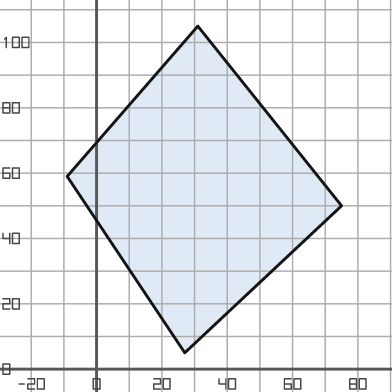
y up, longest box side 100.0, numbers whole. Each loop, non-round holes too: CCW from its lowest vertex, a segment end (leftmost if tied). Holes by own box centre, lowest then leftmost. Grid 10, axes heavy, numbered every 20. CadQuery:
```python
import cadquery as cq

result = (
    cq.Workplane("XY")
    .moveTo(27.0, 5.0)
    .lineTo(75.0, 50.0)
    .lineTo(31.0, 105.0)
    .lineTo(-9.0, 59.0)
    .close()
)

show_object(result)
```